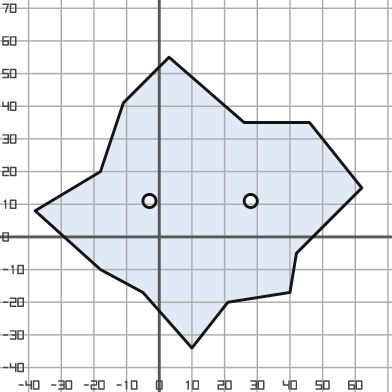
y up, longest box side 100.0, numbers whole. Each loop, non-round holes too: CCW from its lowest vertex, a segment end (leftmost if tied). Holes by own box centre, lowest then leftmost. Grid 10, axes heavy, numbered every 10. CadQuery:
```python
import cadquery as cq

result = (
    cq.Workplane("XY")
    .moveTo(10.0, -34.0)
    .lineTo(21.0, -20.0)
    .lineTo(40.0, -17.0)
    .lineTo(42.0, -5.0)
    .lineTo(62.0, 15.0)
    .lineTo(46.0, 35.0)
    .lineTo(26.0, 35.0)
    .lineTo(3.0, 55.0)
    .lineTo(-11.0, 41.0)
    .lineTo(-18.0, 20.0)
    .lineTo(-38.0, 8.0)
    .lineTo(-18.0, -10.0)
    .lineTo(-5.0, -17.0)
    .close()
    .moveTo(-3.0, 11.0)
    .circle(2.0)
    .moveTo(28.0, 11.0)
    .circle(2.0)
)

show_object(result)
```